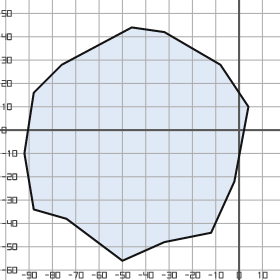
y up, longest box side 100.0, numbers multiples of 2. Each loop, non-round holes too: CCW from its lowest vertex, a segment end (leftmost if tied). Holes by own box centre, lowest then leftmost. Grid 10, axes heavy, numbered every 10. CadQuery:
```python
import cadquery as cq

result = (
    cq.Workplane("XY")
    .moveTo(-50.0, -56.0)
    .lineTo(-32.0, -48.0)
    .lineTo(-12.0, -44.0)
    .lineTo(-2.0, -22.0)
    .lineTo(4.0, 10.0)
    .lineTo(-8.0, 28.0)
    .lineTo(-32.0, 42.0)
    .lineTo(-46.0, 44.0)
    .lineTo(-76.0, 28.0)
    .lineTo(-88.0, 16.0)
    .lineTo(-92.0, -10.0)
    .lineTo(-88.0, -34.0)
    .lineTo(-74.0, -38.0)
    .close()
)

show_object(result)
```